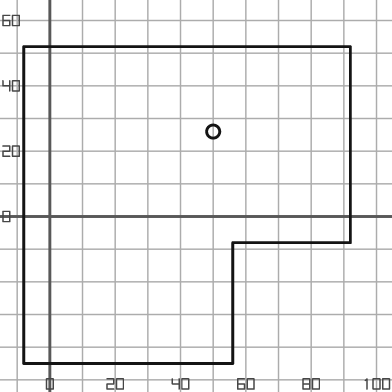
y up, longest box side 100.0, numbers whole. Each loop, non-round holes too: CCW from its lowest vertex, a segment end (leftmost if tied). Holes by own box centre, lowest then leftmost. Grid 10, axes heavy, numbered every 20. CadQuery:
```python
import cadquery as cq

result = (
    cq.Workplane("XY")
    .moveTo(-8.0, -45.0)
    .lineTo(56.0, -45.0)
    .lineTo(56.0, -8.0)
    .lineTo(92.0, -8.0)
    .lineTo(92.0, 52.0)
    .lineTo(-8.0, 52.0)
    .close()
    .moveTo(50.0, 26.0)
    .circle(2.0)
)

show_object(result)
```